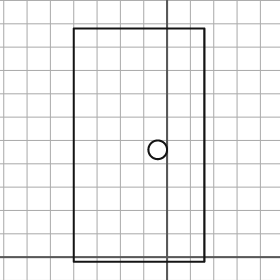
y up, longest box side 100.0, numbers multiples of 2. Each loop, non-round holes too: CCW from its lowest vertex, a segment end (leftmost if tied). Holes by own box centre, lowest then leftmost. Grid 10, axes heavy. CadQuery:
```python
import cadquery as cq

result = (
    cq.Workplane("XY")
    .moveTo(-40.0, -2.0)
    .lineTo(16.0, -2.0)
    .lineTo(16.0, 98.0)
    .lineTo(-40.0, 98.0)
    .close()
    .moveTo(-4.0, 46.0)
    .circle(4.0)
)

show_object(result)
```